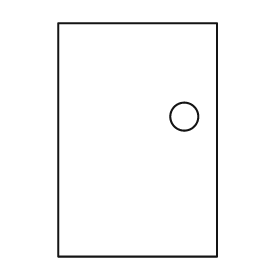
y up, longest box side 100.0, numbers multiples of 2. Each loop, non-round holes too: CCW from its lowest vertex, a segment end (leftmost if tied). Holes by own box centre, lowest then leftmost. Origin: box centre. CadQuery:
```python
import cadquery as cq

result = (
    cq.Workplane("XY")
    .moveTo(-34.0, -50.0)
    .lineTo(34.0, -50.0)
    .lineTo(34.0, 50.0)
    .lineTo(-34.0, 50.0)
    .close()
    .moveTo(20.0, 10.0)
    .circle(6.0)
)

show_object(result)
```